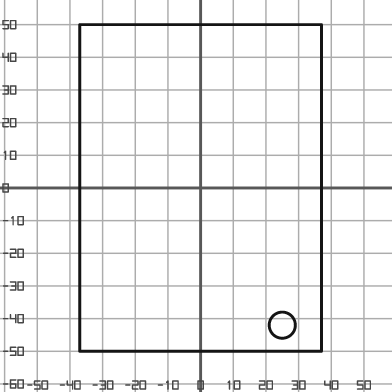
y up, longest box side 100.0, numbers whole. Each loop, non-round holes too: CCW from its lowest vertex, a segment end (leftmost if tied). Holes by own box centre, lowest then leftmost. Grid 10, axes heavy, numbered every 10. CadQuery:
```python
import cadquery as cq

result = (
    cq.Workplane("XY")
    .moveTo(-37.0, -50.0)
    .lineTo(37.0, -50.0)
    .lineTo(37.0, 50.0)
    .lineTo(-37.0, 50.0)
    .close()
    .moveTo(25.0, -42.0)
    .circle(4.0)
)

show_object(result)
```